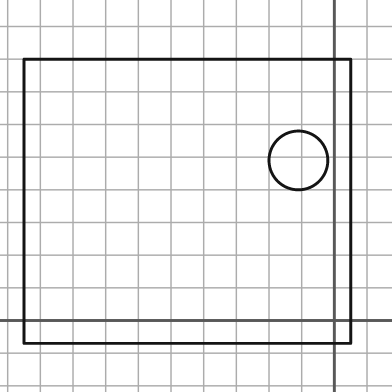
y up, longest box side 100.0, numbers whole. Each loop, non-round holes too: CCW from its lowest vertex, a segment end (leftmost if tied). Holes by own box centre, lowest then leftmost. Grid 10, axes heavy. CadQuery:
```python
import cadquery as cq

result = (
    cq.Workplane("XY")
    .moveTo(-95.0, -7.0)
    .lineTo(5.0, -7.0)
    .lineTo(5.0, 80.0)
    .lineTo(-95.0, 80.0)
    .close()
    .moveTo(-11.0, 49.0)
    .circle(9.0)
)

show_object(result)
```